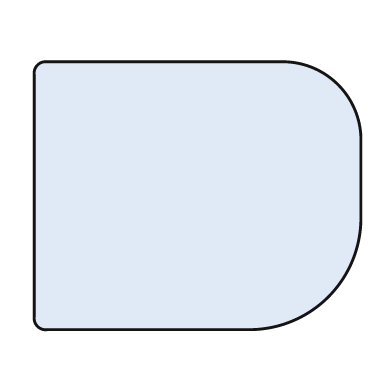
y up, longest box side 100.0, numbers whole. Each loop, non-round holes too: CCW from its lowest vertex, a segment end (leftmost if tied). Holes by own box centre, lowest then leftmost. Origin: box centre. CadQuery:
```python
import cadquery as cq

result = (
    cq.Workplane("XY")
    .moveTo(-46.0, -41.0)
    .lineTo(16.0, -41.0)
    .threePointArc((40.0, -31.0), (50.0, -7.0))
    .lineTo(50.0, 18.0)
    .threePointArc((43.0, 34.0), (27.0, 41.0))
    .lineTo(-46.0, 41.0)
    .threePointArc((-49.0, 40.0), (-50.0, 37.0))
    .lineTo(-50.0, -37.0)
    .threePointArc((-49.0, -40.0), (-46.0, -41.0))
    .close()
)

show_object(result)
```